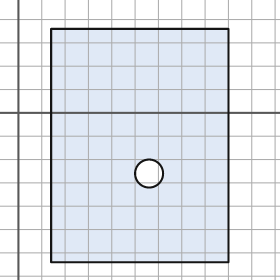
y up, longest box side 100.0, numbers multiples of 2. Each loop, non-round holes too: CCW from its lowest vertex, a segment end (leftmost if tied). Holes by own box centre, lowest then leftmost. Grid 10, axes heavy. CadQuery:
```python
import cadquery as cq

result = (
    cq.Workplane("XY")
    .moveTo(14.0, -64.0)
    .lineTo(90.0, -64.0)
    .lineTo(90.0, 36.0)
    .lineTo(14.0, 36.0)
    .close()
    .moveTo(56.0, -26.0)
    .circle(6.0)
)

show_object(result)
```